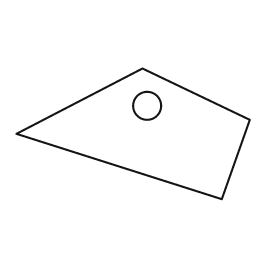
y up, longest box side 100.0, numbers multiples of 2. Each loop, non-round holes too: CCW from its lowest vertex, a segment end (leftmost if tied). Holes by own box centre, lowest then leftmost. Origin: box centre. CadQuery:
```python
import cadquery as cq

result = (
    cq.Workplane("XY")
    .moveTo(38.0, -28.0)
    .lineTo(50.0, 6.0)
    .lineTo(4.0, 28.0)
    .lineTo(-50.0, 0.0)
    .close()
    .moveTo(6.0, 12.0)
    .circle(6.0)
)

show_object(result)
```